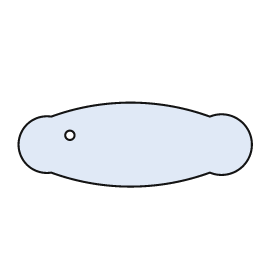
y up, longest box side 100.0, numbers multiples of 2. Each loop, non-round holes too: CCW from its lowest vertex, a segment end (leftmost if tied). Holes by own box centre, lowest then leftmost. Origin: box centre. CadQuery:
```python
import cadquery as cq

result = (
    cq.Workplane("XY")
    .moveTo(-36.0, -12.0)
    .threePointArc((-2.0, -18.0), (32.0, -12.0))
    .threePointArc((50.0, 0.0), (32.0, 12.0))
    .threePointArc((-2.0, 18.0), (-36.0, 12.0))
    .threePointArc((-50.0, 0.0), (-36.0, -12.0))
    .close()
    .moveTo(-28.0, 4.0)
    .circle(2.0)
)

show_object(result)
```